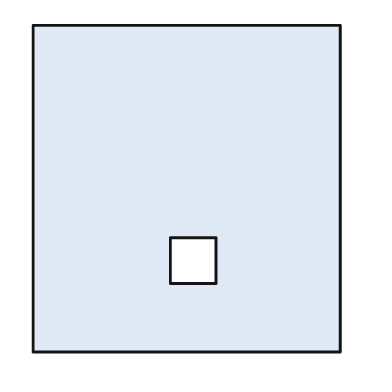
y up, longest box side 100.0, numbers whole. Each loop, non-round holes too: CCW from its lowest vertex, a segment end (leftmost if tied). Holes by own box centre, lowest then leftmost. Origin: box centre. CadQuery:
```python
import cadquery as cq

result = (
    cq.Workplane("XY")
    .moveTo(-47.0, -50.0)
    .lineTo(47.0, -50.0)
    .lineTo(47.0, 50.0)
    .lineTo(-47.0, 50.0)
    .close()
    .moveTo(-5.0, -29.0)
    .lineTo(9.0, -29.0)
    .lineTo(9.0, -15.0)
    .lineTo(-5.0, -15.0)
    .close()
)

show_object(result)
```